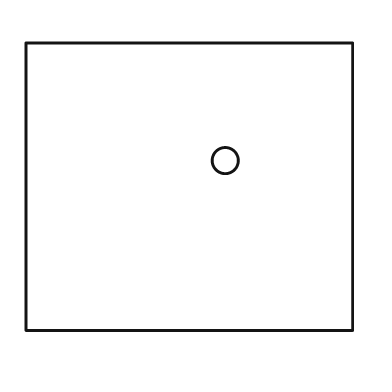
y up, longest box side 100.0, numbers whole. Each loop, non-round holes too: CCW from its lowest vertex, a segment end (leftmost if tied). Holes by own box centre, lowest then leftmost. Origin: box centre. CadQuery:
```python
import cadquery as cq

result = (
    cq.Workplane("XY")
    .moveTo(-50.0, -44.0)
    .lineTo(50.0, -44.0)
    .lineTo(50.0, 44.0)
    .lineTo(-50.0, 44.0)
    .close()
    .moveTo(11.0, 8.0)
    .circle(4.0)
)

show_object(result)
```